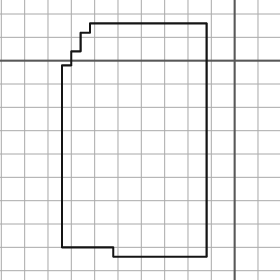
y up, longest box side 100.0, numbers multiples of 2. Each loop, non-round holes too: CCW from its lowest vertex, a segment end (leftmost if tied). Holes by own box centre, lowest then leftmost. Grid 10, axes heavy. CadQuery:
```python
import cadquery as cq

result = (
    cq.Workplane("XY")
    .moveTo(-52.0, -84.0)
    .lineTo(-12.0, -84.0)
    .lineTo(-12.0, 16.0)
    .lineTo(-62.0, 16.0)
    .lineTo(-62.0, 12.0)
    .lineTo(-66.0, 12.0)
    .lineTo(-66.0, 4.0)
    .lineTo(-70.0, 4.0)
    .lineTo(-70.0, -2.0)
    .lineTo(-74.0, -2.0)
    .lineTo(-74.0, -80.0)
    .lineTo(-52.0, -80.0)
    .close()
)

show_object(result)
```